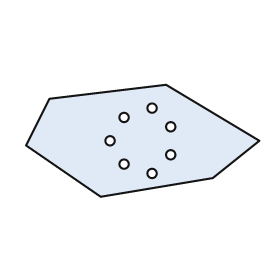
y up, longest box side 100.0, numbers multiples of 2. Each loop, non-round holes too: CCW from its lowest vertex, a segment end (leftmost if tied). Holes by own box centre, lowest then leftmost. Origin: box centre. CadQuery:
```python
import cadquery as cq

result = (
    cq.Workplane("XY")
    .moveTo(-18.0, -24.0)
    .lineTo(30.0, -16.0)
    .lineTo(50.0, 0.0)
    .lineTo(10.0, 24.0)
    .lineTo(-40.0, 18.0)
    .lineTo(-50.0, -2.0)
    .close()
    .moveTo(4.0, -14.0)
    .circle(2.0)
    .moveTo(-8.0, -10.0)
    .circle(2.0)
    .moveTo(12.0, -6.0)
    .circle(2.0)
    .moveTo(-14.0, 0.0)
    .circle(2.0)
    .moveTo(12.0, 6.0)
    .circle(2.0)
    .moveTo(-8.0, 10.0)
    .circle(2.0)
    .moveTo(4.0, 14.0)
    .circle(2.0)
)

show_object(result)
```